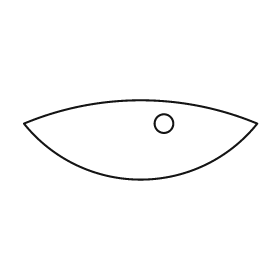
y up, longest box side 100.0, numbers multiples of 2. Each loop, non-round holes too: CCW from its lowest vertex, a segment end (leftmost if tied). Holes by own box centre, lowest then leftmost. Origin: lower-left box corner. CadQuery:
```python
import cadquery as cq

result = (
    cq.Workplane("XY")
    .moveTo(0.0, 24.0)
    .threePointArc((50.0, 0.0), (100.0, 24.0))
    .threePointArc((50.0, 34.0), (0.0, 24.0))
    .close()
    .moveTo(60.0, 24.0)
    .circle(4.0)
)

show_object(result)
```